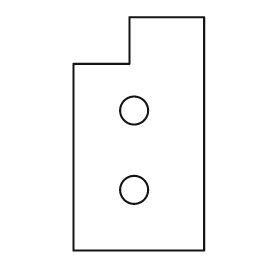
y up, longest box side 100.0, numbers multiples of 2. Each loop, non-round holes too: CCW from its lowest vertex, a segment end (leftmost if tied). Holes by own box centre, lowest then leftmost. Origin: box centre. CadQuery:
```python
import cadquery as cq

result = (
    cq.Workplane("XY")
    .moveTo(-28.0, -50.0)
    .lineTo(28.0, -50.0)
    .lineTo(28.0, 50.0)
    .lineTo(-4.0, 50.0)
    .lineTo(-4.0, 30.0)
    .lineTo(-28.0, 30.0)
    .close()
    .moveTo(-2.0, -24.0)
    .circle(6.0)
    .moveTo(-2.0, 10.0)
    .circle(6.0)
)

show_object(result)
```